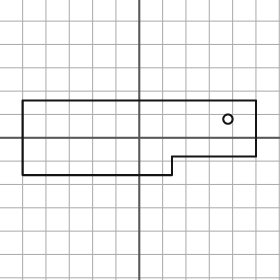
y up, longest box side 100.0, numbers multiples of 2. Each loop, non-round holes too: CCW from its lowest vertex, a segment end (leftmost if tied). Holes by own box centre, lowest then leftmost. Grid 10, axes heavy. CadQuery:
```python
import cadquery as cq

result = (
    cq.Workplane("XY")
    .moveTo(-50.0, -16.0)
    .lineTo(14.0, -16.0)
    .lineTo(14.0, -8.0)
    .lineTo(50.0, -8.0)
    .lineTo(50.0, 16.0)
    .lineTo(-50.0, 16.0)
    .close()
    .moveTo(38.0, 8.0)
    .circle(2.0)
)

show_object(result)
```